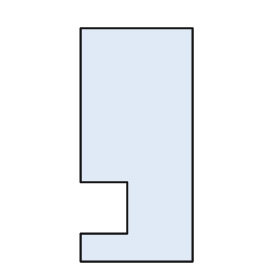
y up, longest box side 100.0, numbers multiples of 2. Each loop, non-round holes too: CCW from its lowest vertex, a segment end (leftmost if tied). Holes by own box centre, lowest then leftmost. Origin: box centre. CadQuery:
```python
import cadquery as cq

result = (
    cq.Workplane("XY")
    .moveTo(-24.0, -50.0)
    .lineTo(24.0, -50.0)
    .lineTo(24.0, 50.0)
    .lineTo(-24.0, 50.0)
    .lineTo(-24.0, -16.0)
    .lineTo(-4.0, -16.0)
    .lineTo(-4.0, -38.0)
    .lineTo(-24.0, -38.0)
    .close()
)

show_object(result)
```